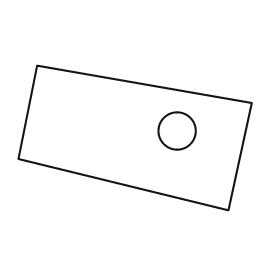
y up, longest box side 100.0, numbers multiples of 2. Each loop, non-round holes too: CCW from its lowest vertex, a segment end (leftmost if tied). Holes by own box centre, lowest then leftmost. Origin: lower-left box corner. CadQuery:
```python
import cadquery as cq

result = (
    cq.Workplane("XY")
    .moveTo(90.0, 0.0)
    .lineTo(100.0, 46.0)
    .lineTo(8.0, 62.0)
    .lineTo(0.0, 22.0)
    .close()
    .moveTo(68.0, 34.0)
    .circle(8.0)
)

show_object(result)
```